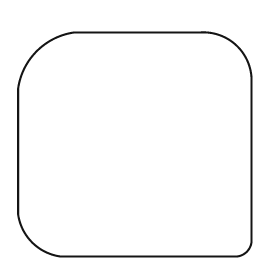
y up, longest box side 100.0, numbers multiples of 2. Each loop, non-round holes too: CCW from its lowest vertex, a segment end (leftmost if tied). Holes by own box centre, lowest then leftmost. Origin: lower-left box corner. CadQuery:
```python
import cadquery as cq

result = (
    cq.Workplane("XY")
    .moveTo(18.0, 0.0)
    .lineTo(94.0, 0.0)
    .threePointArc((98.0, 2.0), (100.0, 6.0))
    .lineTo(100.0, 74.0)
    .threePointArc((94.0, 90.0), (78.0, 96.0))
    .lineTo(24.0, 96.0)
    .threePointArc((8.0, 88.0), (0.0, 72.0))
    .lineTo(0.0, 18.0)
    .threePointArc((6.0, 6.0), (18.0, 0.0))
    .close()
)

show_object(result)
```